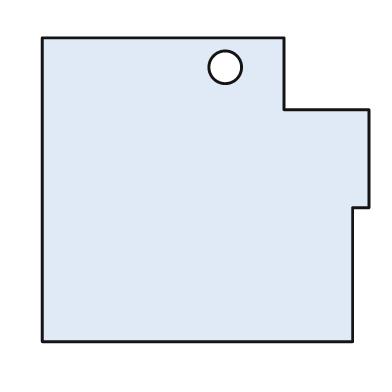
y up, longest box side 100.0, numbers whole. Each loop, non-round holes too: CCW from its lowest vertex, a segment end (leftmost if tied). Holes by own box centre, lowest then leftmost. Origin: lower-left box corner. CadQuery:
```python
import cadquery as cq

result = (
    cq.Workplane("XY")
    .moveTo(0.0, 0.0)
    .lineTo(95.0, 0.0)
    .lineTo(95.0, 41.0)
    .lineTo(100.0, 41.0)
    .lineTo(100.0, 71.0)
    .lineTo(74.0, 71.0)
    .lineTo(74.0, 93.0)
    .lineTo(0.0, 93.0)
    .close()
    .moveTo(56.0, 84.0)
    .circle(5.0)
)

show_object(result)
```